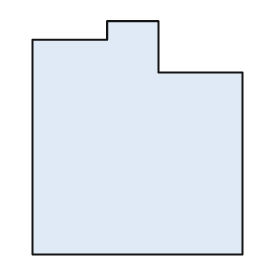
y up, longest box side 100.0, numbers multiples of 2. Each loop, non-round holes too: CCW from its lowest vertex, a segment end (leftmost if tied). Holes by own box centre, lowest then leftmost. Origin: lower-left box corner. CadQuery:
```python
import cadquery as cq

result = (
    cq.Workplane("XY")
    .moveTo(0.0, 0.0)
    .lineTo(90.0, 0.0)
    .lineTo(90.0, 78.0)
    .lineTo(54.0, 78.0)
    .lineTo(54.0, 100.0)
    .lineTo(32.0, 100.0)
    .lineTo(32.0, 92.0)
    .lineTo(0.0, 92.0)
    .close()
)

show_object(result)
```